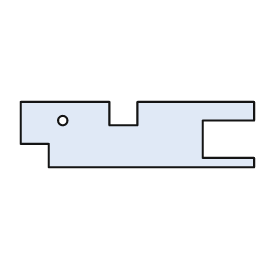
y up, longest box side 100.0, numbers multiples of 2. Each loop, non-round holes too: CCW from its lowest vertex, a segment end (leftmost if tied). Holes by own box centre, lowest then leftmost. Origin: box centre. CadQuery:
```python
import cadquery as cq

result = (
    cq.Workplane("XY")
    .moveTo(-38.0, -14.0)
    .lineTo(50.0, -14.0)
    .lineTo(50.0, -10.0)
    .lineTo(28.0, -10.0)
    .lineTo(28.0, 6.0)
    .lineTo(50.0, 6.0)
    .lineTo(50.0, 14.0)
    .lineTo(0.0, 14.0)
    .lineTo(0.0, 4.0)
    .lineTo(-12.0, 4.0)
    .lineTo(-12.0, 14.0)
    .lineTo(-50.0, 14.0)
    .lineTo(-50.0, -4.0)
    .lineTo(-38.0, -4.0)
    .close()
    .moveTo(-32.0, 6.0)
    .circle(2.0)
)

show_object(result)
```